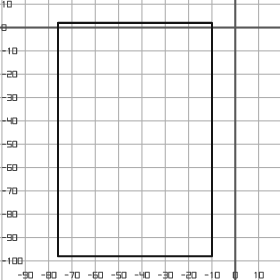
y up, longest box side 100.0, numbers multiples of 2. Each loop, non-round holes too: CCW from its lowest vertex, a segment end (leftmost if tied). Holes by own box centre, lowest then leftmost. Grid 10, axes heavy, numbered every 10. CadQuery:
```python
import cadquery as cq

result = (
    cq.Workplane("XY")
    .moveTo(-76.0, -98.0)
    .lineTo(-10.0, -98.0)
    .lineTo(-10.0, 2.0)
    .lineTo(-76.0, 2.0)
    .close()
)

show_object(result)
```